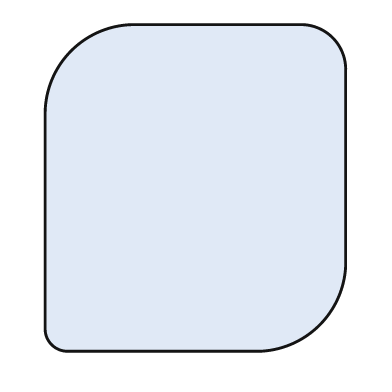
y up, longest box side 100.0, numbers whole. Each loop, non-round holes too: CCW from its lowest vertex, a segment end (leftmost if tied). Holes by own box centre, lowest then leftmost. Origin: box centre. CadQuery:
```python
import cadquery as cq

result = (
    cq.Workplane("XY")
    .moveTo(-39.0, -50.0)
    .lineTo(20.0, -50.0)
    .threePointArc((38.0, -42.0), (46.0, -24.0))
    .lineTo(46.0, 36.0)
    .threePointArc((42.0, 46.0), (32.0, 50.0))
    .lineTo(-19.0, 50.0)
    .threePointArc((-38.0, 42.0), (-46.0, 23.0))
    .lineTo(-46.0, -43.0)
    .threePointArc((-44.0, -48.0), (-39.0, -50.0))
    .close()
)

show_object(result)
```